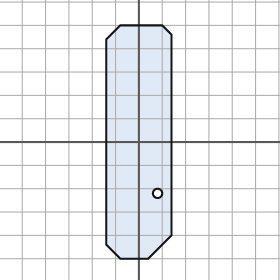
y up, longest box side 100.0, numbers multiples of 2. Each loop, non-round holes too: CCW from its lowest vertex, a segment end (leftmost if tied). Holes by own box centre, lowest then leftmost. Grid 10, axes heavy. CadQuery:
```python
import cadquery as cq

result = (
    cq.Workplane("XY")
    .moveTo(-8.0, -50.0)
    .lineTo(4.0, -50.0)
    .lineTo(14.0, -40.0)
    .lineTo(14.0, 46.0)
    .lineTo(10.0, 50.0)
    .lineTo(-8.0, 50.0)
    .lineTo(-14.0, 44.0)
    .lineTo(-14.0, -44.0)
    .close()
    .moveTo(8.0, -22.0)
    .circle(2.0)
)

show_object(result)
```